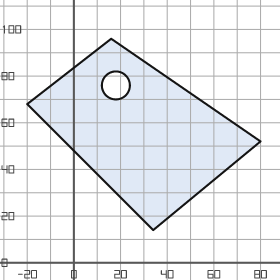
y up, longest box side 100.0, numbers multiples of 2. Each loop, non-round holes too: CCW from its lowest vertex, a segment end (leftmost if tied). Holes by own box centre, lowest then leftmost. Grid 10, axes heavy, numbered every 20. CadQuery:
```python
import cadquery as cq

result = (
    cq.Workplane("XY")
    .moveTo(34.0, 14.0)
    .lineTo(80.0, 52.0)
    .lineTo(16.0, 96.0)
    .lineTo(-20.0, 68.0)
    .close()
    .moveTo(18.0, 76.0)
    .circle(6.0)
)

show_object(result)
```